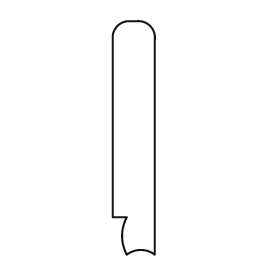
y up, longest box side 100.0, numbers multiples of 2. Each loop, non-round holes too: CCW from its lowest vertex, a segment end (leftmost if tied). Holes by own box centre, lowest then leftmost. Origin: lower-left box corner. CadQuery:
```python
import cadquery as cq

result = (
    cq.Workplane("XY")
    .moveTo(6.0, 0.0)
    .threePointArc((12.0, 2.0), (18.0, 0.0))
    .lineTo(18.0, 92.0)
    .threePointArc((16.0, 98.0), (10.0, 100.0))
    .lineTo(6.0, 100.0)
    .threePointArc((2.0, 98.0), (0.0, 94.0))
    .lineTo(0.0, 16.0)
    .lineTo(6.0, 16.0)
    .threePointArc((4.0, 8.0), (6.0, 0.0))
    .close()
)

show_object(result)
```